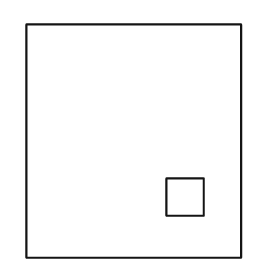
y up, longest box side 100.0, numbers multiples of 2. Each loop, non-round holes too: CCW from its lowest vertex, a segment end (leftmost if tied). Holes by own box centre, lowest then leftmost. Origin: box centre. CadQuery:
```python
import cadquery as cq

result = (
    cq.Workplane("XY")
    .moveTo(-46.0, -50.0)
    .lineTo(46.0, -50.0)
    .lineTo(46.0, 50.0)
    .lineTo(-46.0, 50.0)
    .close()
    .moveTo(14.0, -32.0)
    .lineTo(30.0, -32.0)
    .lineTo(30.0, -16.0)
    .lineTo(14.0, -16.0)
    .close()
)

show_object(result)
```